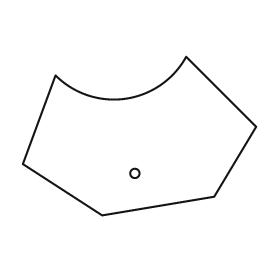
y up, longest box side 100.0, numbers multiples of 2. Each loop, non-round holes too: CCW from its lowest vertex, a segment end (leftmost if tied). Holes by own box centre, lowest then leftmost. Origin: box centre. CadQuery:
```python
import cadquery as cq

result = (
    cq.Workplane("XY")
    .moveTo(-16.0, -34.0)
    .lineTo(32.0, -26.0)
    .lineTo(50.0, 4.0)
    .lineTo(20.0, 34.0)
    .threePointArc((-6.0, 16.0), (-36.0, 26.0))
    .lineTo(-50.0, -12.0)
    .close()
    .moveTo(-2.0, -16.0)
    .circle(2.0)
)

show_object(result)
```